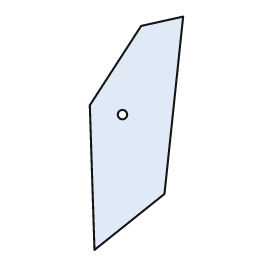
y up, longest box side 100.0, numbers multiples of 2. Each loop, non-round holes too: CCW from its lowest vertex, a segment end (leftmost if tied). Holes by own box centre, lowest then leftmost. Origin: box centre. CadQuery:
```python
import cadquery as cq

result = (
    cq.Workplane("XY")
    .moveTo(-18.0, -50.0)
    .lineTo(12.0, -26.0)
    .lineTo(20.0, 50.0)
    .lineTo(2.0, 46.0)
    .lineTo(-20.0, 12.0)
    .close()
    .moveTo(-6.0, 8.0)
    .circle(2.0)
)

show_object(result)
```